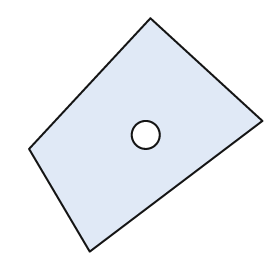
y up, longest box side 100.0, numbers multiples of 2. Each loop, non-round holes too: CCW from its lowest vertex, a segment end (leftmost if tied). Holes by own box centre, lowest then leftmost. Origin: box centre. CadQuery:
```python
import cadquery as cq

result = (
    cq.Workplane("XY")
    .moveTo(-24.0, -50.0)
    .lineTo(50.0, 6.0)
    .lineTo(2.0, 50.0)
    .lineTo(-50.0, -6.0)
    .close()
    .moveTo(0.0, 0.0)
    .circle(6.0)
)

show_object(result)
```